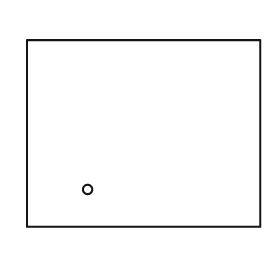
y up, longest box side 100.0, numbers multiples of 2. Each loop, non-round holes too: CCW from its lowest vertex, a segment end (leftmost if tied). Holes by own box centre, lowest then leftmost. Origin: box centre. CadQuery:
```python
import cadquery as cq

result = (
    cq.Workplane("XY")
    .moveTo(-50.0, -40.0)
    .lineTo(50.0, -40.0)
    .lineTo(50.0, 40.0)
    .lineTo(-50.0, 40.0)
    .close()
    .moveTo(-24.0, -24.0)
    .circle(2.0)
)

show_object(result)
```